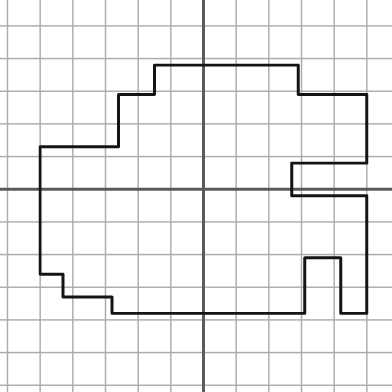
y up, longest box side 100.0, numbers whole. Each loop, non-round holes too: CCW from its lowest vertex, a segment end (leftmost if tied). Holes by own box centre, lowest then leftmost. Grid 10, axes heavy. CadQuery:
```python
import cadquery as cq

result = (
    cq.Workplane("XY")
    .moveTo(-28.0, -38.0)
    .lineTo(31.0, -38.0)
    .lineTo(31.0, -21.0)
    .lineTo(42.0, -21.0)
    .lineTo(42.0, -38.0)
    .lineTo(50.0, -38.0)
    .lineTo(50.0, -2.0)
    .lineTo(27.0, -2.0)
    .lineTo(27.0, 8.0)
    .lineTo(50.0, 8.0)
    .lineTo(50.0, 29.0)
    .lineTo(29.0, 29.0)
    .lineTo(29.0, 38.0)
    .lineTo(-15.0, 38.0)
    .lineTo(-15.0, 29.0)
    .lineTo(-26.0, 29.0)
    .lineTo(-26.0, 13.0)
    .lineTo(-50.0, 13.0)
    .lineTo(-50.0, -26.0)
    .lineTo(-43.0, -26.0)
    .lineTo(-43.0, -33.0)
    .lineTo(-28.0, -33.0)
    .close()
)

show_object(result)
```